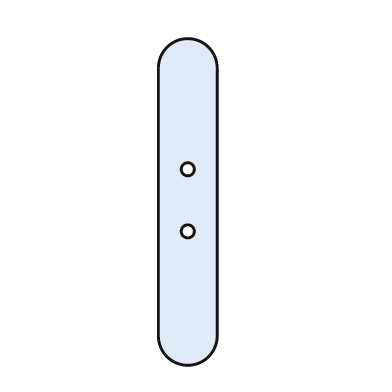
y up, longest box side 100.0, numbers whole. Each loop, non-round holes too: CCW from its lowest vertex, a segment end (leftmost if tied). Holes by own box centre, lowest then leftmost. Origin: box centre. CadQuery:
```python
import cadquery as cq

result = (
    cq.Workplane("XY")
    .moveTo(-9.0, -41.0)
    .threePointArc((0.0, -50.0), (9.0, -41.0))
    .lineTo(9.0, 41.0)
    .threePointArc((0.0, 50.0), (-9.0, 41.0))
    .close()
    .moveTo(0.0, -9.0)
    .circle(2.0)
    .moveTo(0.0, 10.0)
    .circle(2.0)
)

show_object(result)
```